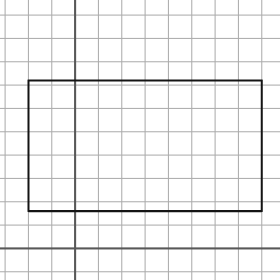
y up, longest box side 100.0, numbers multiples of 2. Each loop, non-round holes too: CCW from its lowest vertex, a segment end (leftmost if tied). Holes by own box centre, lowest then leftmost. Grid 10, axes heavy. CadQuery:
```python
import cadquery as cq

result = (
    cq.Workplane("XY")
    .moveTo(-20.0, 16.0)
    .lineTo(80.0, 16.0)
    .lineTo(80.0, 72.0)
    .lineTo(-20.0, 72.0)
    .close()
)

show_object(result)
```